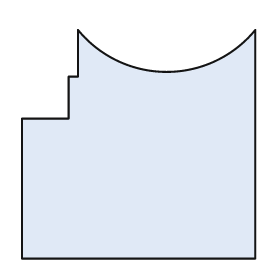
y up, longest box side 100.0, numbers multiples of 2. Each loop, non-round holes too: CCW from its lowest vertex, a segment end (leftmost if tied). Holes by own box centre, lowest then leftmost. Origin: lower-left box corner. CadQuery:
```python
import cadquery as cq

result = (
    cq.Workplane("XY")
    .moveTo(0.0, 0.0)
    .lineTo(100.0, 0.0)
    .lineTo(100.0, 98.0)
    .threePointArc((62.0, 80.0), (24.0, 98.0))
    .lineTo(24.0, 78.0)
    .lineTo(20.0, 78.0)
    .lineTo(20.0, 60.0)
    .lineTo(0.0, 60.0)
    .close()
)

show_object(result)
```